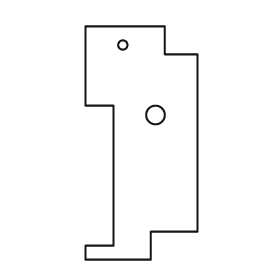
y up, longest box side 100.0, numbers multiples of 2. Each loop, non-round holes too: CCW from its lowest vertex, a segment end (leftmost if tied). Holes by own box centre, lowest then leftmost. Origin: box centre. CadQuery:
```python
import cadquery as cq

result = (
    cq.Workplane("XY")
    .moveTo(-24.0, -50.0)
    .lineTo(4.0, -50.0)
    .lineTo(4.0, -38.0)
    .lineTo(24.0, -38.0)
    .lineTo(24.0, 38.0)
    .lineTo(10.0, 38.0)
    .lineTo(10.0, 50.0)
    .lineTo(-24.0, 50.0)
    .lineTo(-24.0, 16.0)
    .lineTo(-12.0, 16.0)
    .lineTo(-12.0, -44.0)
    .lineTo(-24.0, -44.0)
    .close()
    .moveTo(6.0, 12.0)
    .circle(4.0)
    .moveTo(-8.0, 42.0)
    .circle(2.0)
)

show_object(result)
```